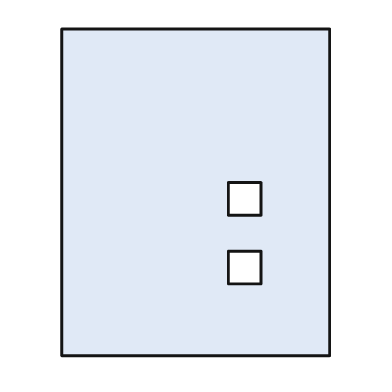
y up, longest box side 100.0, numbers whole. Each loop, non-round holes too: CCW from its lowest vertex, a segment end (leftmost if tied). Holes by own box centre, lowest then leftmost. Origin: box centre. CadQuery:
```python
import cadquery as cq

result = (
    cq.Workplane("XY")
    .moveTo(-41.0, -50.0)
    .lineTo(41.0, -50.0)
    .lineTo(41.0, 50.0)
    .lineTo(-41.0, 50.0)
    .close()
    .moveTo(10.0, -28.0)
    .lineTo(20.0, -28.0)
    .lineTo(20.0, -18.0)
    .lineTo(10.0, -18.0)
    .close()
    .moveTo(10.0, -7.0)
    .lineTo(20.0, -7.0)
    .lineTo(20.0, 3.0)
    .lineTo(10.0, 3.0)
    .close()
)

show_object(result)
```